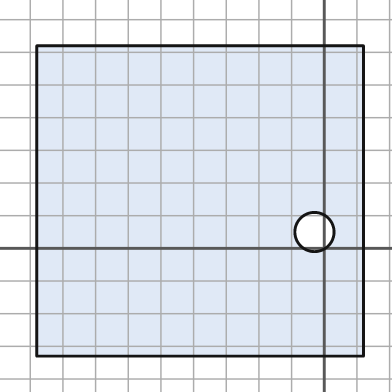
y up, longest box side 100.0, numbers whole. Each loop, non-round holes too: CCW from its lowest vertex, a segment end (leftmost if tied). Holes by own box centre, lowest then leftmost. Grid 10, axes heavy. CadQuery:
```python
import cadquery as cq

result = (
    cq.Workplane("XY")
    .moveTo(-88.0, -33.0)
    .lineTo(12.0, -33.0)
    .lineTo(12.0, 62.0)
    .lineTo(-88.0, 62.0)
    .close()
    .moveTo(-3.0, 5.0)
    .circle(6.0)
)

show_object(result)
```